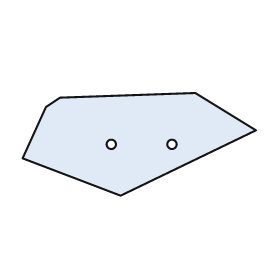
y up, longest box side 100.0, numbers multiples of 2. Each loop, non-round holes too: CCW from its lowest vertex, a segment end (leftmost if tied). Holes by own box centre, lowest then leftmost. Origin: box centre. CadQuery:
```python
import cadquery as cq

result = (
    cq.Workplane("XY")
    .moveTo(-8.0, -22.0)
    .lineTo(50.0, 6.0)
    .lineTo(24.0, 22.0)
    .lineTo(-34.0, 20.0)
    .lineTo(-40.0, 16.0)
    .lineTo(-50.0, -6.0)
    .close()
    .moveTo(-12.0, 0.0)
    .circle(2.0)
    .moveTo(14.0, 0.0)
    .circle(2.0)
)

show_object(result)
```